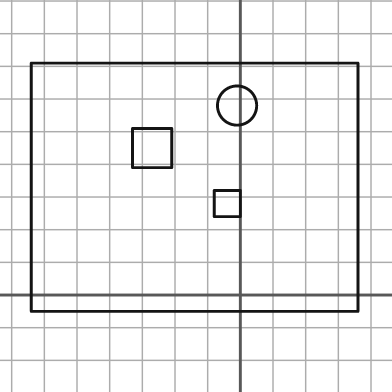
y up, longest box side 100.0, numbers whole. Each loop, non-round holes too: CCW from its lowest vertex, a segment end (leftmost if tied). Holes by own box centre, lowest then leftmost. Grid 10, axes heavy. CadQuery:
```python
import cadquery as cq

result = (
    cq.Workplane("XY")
    .moveTo(-64.0, -5.0)
    .lineTo(36.0, -5.0)
    .lineTo(36.0, 71.0)
    .lineTo(-64.0, 71.0)
    .close()
    .moveTo(-8.0, 24.0)
    .lineTo(0.0, 24.0)
    .lineTo(0.0, 32.0)
    .lineTo(-8.0, 32.0)
    .close()
    .moveTo(-33.0, 39.0)
    .lineTo(-21.0, 39.0)
    .lineTo(-21.0, 51.0)
    .lineTo(-33.0, 51.0)
    .close()
    .moveTo(-1.0, 58.0)
    .circle(6.0)
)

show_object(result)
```